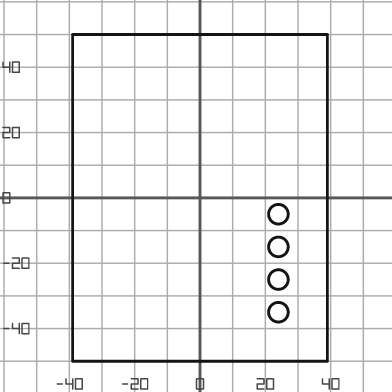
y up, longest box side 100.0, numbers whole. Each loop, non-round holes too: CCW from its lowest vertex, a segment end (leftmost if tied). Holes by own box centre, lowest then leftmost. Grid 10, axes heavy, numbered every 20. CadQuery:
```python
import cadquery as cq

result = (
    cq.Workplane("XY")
    .moveTo(-39.0, -50.0)
    .lineTo(39.0, -50.0)
    .lineTo(39.0, 50.0)
    .lineTo(-39.0, 50.0)
    .close()
    .moveTo(24.0, -35.0)
    .circle(3.0)
    .moveTo(24.0, -25.0)
    .circle(3.0)
    .moveTo(24.0, -15.0)
    .circle(3.0)
    .moveTo(24.0, -5.0)
    .circle(3.0)
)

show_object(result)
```